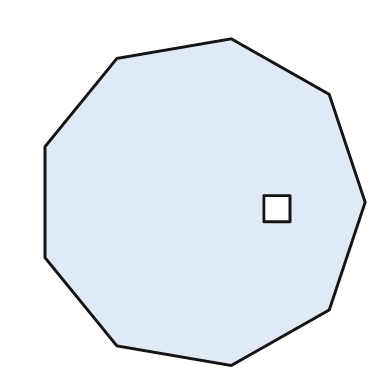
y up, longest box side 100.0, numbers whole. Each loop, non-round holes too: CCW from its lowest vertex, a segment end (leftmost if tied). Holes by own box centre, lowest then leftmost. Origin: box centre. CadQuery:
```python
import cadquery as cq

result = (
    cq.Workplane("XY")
    .moveTo(8.0, -50.0)
    .lineTo(38.0, -33.0)
    .lineTo(49.0, 0.0)
    .lineTo(38.0, 33.0)
    .lineTo(8.0, 50.0)
    .lineTo(-27.0, 44.0)
    .lineTo(-49.0, 17.0)
    .lineTo(-49.0, -17.0)
    .lineTo(-27.0, -44.0)
    .close()
    .moveTo(18.0, -6.0)
    .lineTo(26.0, -6.0)
    .lineTo(26.0, 2.0)
    .lineTo(18.0, 2.0)
    .close()
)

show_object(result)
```